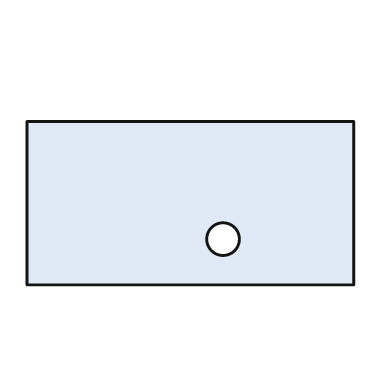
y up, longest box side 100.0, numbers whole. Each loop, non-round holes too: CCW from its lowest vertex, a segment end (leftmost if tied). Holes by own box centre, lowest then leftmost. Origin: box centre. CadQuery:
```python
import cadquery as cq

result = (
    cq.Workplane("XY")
    .moveTo(-50.0, -25.0)
    .lineTo(50.0, -25.0)
    .lineTo(50.0, 25.0)
    .lineTo(-50.0, 25.0)
    .close()
    .moveTo(10.0, -11.0)
    .circle(5.0)
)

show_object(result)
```